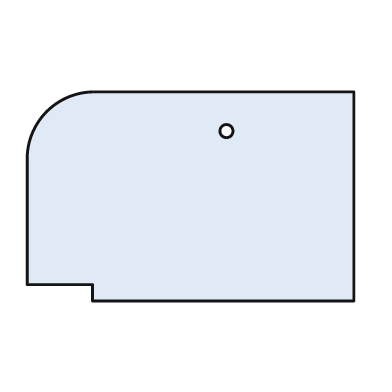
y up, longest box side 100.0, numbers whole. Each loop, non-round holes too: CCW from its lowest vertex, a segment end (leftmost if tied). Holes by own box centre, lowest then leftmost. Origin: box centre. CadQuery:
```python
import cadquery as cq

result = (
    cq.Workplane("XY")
    .moveTo(-30.0, -32.0)
    .lineTo(50.0, -32.0)
    .lineTo(50.0, 32.0)
    .lineTo(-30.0, 32.0)
    .threePointArc((-44.0, 26.0), (-50.0, 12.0))
    .lineTo(-50.0, -27.0)
    .lineTo(-30.0, -27.0)
    .close()
    .moveTo(11.0, 20.0)
    .circle(2.0)
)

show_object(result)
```